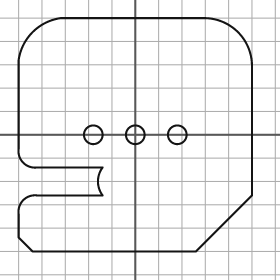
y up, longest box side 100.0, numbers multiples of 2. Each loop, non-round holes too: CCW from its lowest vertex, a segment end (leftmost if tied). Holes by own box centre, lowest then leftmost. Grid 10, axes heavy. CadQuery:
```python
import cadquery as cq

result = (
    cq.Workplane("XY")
    .moveTo(-44.0, -50.0)
    .lineTo(26.0, -50.0)
    .lineTo(50.0, -26.0)
    .lineTo(50.0, 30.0)
    .threePointArc((44.0, 44.0), (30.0, 50.0))
    .lineTo(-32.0, 50.0)
    .threePointArc((-44.0, 44.0), (-50.0, 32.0))
    .lineTo(-50.0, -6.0)
    .threePointArc((-48.0, -12.0), (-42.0, -14.0))
    .lineTo(-14.0, -14.0)
    .threePointArc((-16.0, -20.0), (-14.0, -26.0))
    .lineTo(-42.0, -26.0)
    .threePointArc((-48.0, -28.0), (-50.0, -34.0))
    .lineTo(-50.0, -44.0)
    .close()
    .moveTo(-18.0, 0.0)
    .circle(4.0)
    .moveTo(0.0, 0.0)
    .circle(4.0)
    .moveTo(18.0, 0.0)
    .circle(4.0)
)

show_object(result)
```